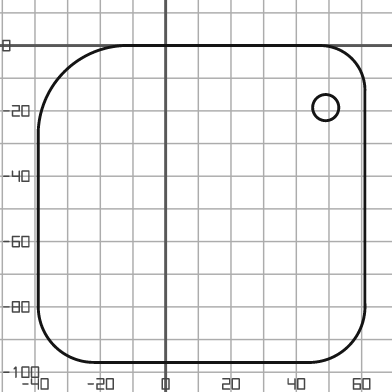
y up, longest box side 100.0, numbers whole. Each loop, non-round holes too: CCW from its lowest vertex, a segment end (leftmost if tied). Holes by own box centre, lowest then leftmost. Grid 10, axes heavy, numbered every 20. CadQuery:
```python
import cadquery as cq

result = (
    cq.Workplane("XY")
    .moveTo(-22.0, -97.0)
    .lineTo(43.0, -97.0)
    .threePointArc((56.0, -92.0), (61.0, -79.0))
    .lineTo(61.0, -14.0)
    .threePointArc((57.0, -4.0), (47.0, 0.0))
    .lineTo(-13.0, 0.0)
    .threePointArc((-31.0, -8.0), (-39.0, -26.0))
    .lineTo(-39.0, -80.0)
    .threePointArc((-34.0, -92.0), (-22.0, -97.0))
    .close()
    .moveTo(49.0, -19.0)
    .circle(4.0)
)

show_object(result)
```